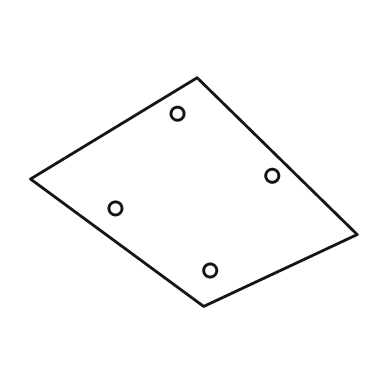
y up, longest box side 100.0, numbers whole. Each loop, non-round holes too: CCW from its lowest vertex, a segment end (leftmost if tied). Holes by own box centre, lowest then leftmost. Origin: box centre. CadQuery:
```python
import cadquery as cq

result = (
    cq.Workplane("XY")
    .moveTo(3.0, -35.0)
    .lineTo(50.0, -13.0)
    .lineTo(1.0, 35.0)
    .lineTo(-50.0, 4.0)
    .close()
    .moveTo(5.0, -24.0)
    .circle(2.0)
    .moveTo(-24.0, -5.0)
    .circle(2.0)
    .moveTo(24.0, 5.0)
    .circle(2.0)
    .moveTo(-5.0, 24.0)
    .circle(2.0)
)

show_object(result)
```